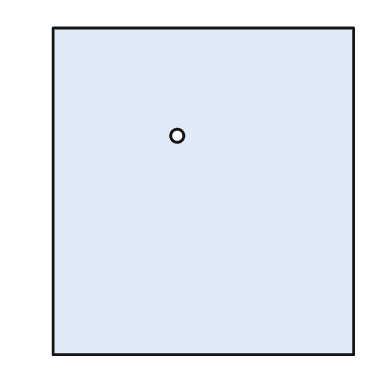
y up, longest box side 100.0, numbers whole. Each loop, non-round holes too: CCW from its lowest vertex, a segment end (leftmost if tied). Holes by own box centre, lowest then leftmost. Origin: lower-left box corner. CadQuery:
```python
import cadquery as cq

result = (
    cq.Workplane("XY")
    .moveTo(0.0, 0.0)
    .lineTo(92.0, 0.0)
    .lineTo(92.0, 100.0)
    .lineTo(0.0, 100.0)
    .close()
    .moveTo(38.0, 67.0)
    .circle(2.0)
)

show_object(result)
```